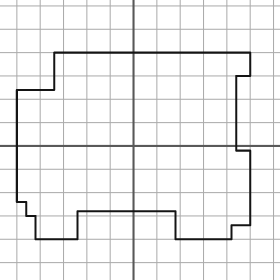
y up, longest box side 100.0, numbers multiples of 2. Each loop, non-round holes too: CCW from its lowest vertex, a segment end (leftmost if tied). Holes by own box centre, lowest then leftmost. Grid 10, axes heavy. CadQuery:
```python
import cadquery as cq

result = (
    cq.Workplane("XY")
    .moveTo(-42.0, -40.0)
    .lineTo(-24.0, -40.0)
    .lineTo(-24.0, -28.0)
    .lineTo(18.0, -28.0)
    .lineTo(18.0, -40.0)
    .lineTo(42.0, -40.0)
    .lineTo(42.0, -34.0)
    .lineTo(50.0, -34.0)
    .lineTo(50.0, -2.0)
    .lineTo(44.0, -2.0)
    .lineTo(44.0, 30.0)
    .lineTo(50.0, 30.0)
    .lineTo(50.0, 40.0)
    .lineTo(-34.0, 40.0)
    .lineTo(-34.0, 24.0)
    .lineTo(-50.0, 24.0)
    .lineTo(-50.0, -24.0)
    .lineTo(-46.0, -24.0)
    .lineTo(-46.0, -30.0)
    .lineTo(-42.0, -30.0)
    .close()
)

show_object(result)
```